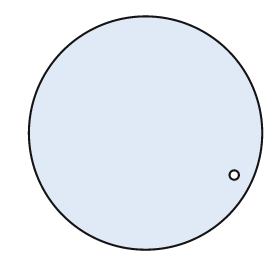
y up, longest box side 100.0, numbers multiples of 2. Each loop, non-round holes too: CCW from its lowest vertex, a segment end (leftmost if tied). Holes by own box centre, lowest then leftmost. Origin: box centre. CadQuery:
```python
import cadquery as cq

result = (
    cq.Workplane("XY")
    .moveTo(0.0, 0.0)
    .circle(50.0)
    .moveTo(38.0, -18.0)
    .circle(2.0)
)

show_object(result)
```